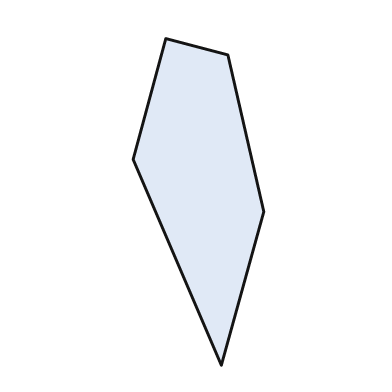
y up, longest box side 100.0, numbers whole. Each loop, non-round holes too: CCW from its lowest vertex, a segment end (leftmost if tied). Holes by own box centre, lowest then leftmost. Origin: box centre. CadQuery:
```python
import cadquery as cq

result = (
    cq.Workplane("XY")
    .moveTo(7.0, -50.0)
    .lineTo(20.0, -3.0)
    .lineTo(9.0, 45.0)
    .lineTo(-10.0, 50.0)
    .lineTo(-20.0, 13.0)
    .close()
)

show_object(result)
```